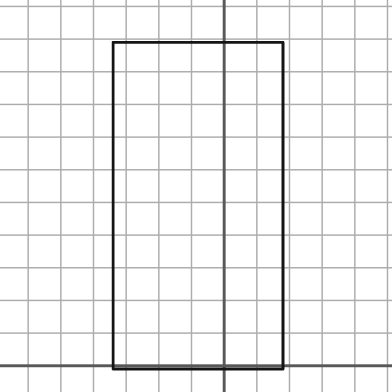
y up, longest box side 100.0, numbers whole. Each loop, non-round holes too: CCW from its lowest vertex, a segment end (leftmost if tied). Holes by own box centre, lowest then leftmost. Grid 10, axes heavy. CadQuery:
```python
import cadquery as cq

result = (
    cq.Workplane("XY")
    .moveTo(-34.0, -1.0)
    .lineTo(18.0, -1.0)
    .lineTo(18.0, 99.0)
    .lineTo(-34.0, 99.0)
    .close()
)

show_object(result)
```